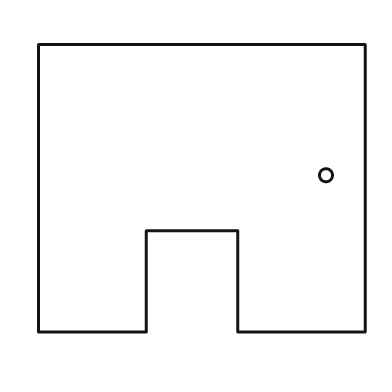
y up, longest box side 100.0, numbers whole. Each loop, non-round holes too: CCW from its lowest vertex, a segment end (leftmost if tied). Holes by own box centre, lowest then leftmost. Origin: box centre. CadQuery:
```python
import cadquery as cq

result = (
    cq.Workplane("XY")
    .moveTo(-50.0, -44.0)
    .lineTo(-17.0, -44.0)
    .lineTo(-17.0, -13.0)
    .lineTo(11.0, -13.0)
    .lineTo(11.0, -44.0)
    .lineTo(50.0, -44.0)
    .lineTo(50.0, 44.0)
    .lineTo(-50.0, 44.0)
    .close()
    .moveTo(38.0, 4.0)
    .circle(2.0)
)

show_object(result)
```